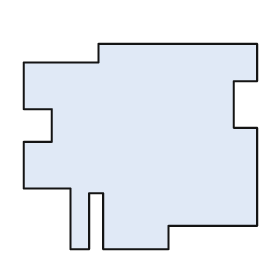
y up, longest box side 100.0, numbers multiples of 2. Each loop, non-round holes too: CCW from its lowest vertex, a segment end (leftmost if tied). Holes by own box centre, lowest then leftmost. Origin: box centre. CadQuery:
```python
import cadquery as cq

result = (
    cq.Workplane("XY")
    .moveTo(-30.0, -44.0)
    .lineTo(-22.0, -44.0)
    .lineTo(-22.0, -20.0)
    .lineTo(-16.0, -20.0)
    .lineTo(-16.0, -44.0)
    .lineTo(12.0, -44.0)
    .lineTo(12.0, -34.0)
    .lineTo(50.0, -34.0)
    .lineTo(50.0, 8.0)
    .lineTo(40.0, 8.0)
    .lineTo(40.0, 28.0)
    .lineTo(50.0, 28.0)
    .lineTo(50.0, 44.0)
    .lineTo(-18.0, 44.0)
    .lineTo(-18.0, 36.0)
    .lineTo(-50.0, 36.0)
    .lineTo(-50.0, 16.0)
    .lineTo(-38.0, 16.0)
    .lineTo(-38.0, 2.0)
    .lineTo(-50.0, 2.0)
    .lineTo(-50.0, -18.0)
    .lineTo(-30.0, -18.0)
    .close()
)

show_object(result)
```